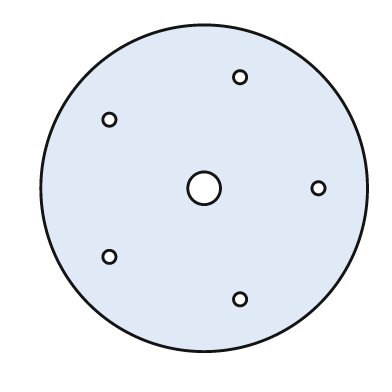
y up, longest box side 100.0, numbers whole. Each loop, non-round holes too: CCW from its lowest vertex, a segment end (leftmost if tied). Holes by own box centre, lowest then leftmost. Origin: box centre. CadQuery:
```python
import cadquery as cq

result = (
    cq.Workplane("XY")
    .moveTo(0.0, 0.0)
    .circle(50.0)
    .moveTo(11.0, -34.0)
    .circle(2.0)
    .moveTo(-29.0, -21.0)
    .circle(2.0)
    .moveTo(0.0, 0.0)
    .circle(5.0)
    .moveTo(35.0, 0.0)
    .circle(2.0)
    .moveTo(-29.0, 21.0)
    .circle(2.0)
    .moveTo(11.0, 34.0)
    .circle(2.0)
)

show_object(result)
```